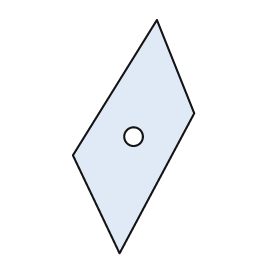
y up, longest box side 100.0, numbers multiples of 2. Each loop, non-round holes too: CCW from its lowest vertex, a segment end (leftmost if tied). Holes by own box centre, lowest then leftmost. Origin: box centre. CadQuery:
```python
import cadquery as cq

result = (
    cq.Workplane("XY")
    .moveTo(-6.0, -50.0)
    .lineTo(26.0, 10.0)
    .lineTo(10.0, 50.0)
    .lineTo(-26.0, -8.0)
    .close()
    .moveTo(0.0, 0.0)
    .circle(4.0)
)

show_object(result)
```